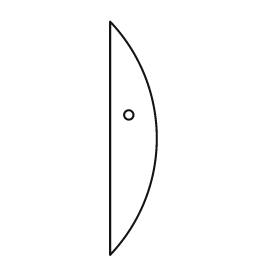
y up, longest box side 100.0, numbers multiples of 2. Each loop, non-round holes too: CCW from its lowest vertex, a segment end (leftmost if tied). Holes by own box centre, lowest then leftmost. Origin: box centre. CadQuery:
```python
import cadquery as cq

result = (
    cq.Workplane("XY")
    .moveTo(-10.0, -50.0)
    .threePointArc((10.0, 0.0), (-10.0, 50.0))
    .close()
    .moveTo(-2.0, 10.0)
    .circle(2.0)
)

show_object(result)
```